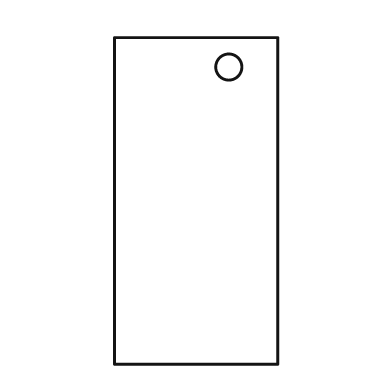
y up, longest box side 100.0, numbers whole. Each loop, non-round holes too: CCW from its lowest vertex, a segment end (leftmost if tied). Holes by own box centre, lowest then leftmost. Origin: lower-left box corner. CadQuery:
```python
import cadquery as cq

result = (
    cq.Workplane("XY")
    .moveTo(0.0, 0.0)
    .lineTo(50.0, 0.0)
    .lineTo(50.0, 100.0)
    .lineTo(0.0, 100.0)
    .close()
    .moveTo(35.0, 91.0)
    .circle(4.0)
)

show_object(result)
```